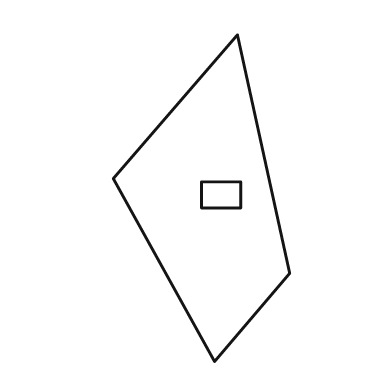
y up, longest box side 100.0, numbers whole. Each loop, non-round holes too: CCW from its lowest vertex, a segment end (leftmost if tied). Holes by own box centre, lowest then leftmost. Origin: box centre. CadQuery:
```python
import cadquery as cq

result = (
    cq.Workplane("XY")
    .moveTo(4.0, -50.0)
    .lineTo(27.0, -23.0)
    .lineTo(11.0, 50.0)
    .lineTo(-27.0, 6.0)
    .close()
    .moveTo(0.0, -3.0)
    .lineTo(12.0, -3.0)
    .lineTo(12.0, 5.0)
    .lineTo(0.0, 5.0)
    .close()
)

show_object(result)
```